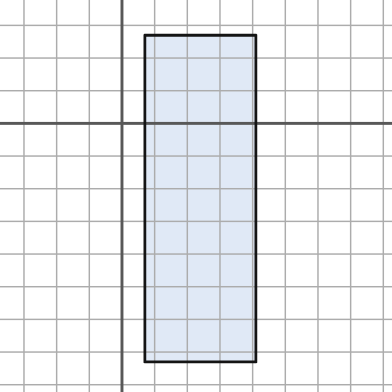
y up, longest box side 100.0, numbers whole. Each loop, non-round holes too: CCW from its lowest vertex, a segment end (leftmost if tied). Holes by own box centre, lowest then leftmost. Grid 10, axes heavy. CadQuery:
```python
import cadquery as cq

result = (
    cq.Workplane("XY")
    .moveTo(7.0, -73.0)
    .lineTo(41.0, -73.0)
    .lineTo(41.0, 27.0)
    .lineTo(7.0, 27.0)
    .close()
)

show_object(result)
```